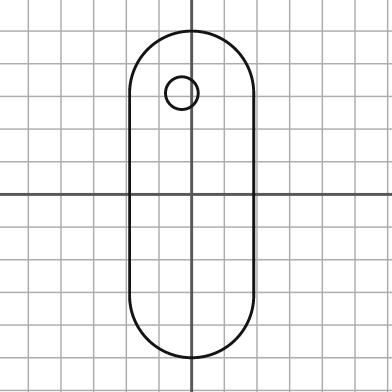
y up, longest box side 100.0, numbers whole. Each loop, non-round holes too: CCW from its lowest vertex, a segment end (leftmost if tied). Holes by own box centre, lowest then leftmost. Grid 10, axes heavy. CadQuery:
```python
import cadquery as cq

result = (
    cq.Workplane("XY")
    .moveTo(-19.0, -31.0)
    .threePointArc((0.0, -50.0), (19.0, -31.0))
    .lineTo(19.0, 31.0)
    .threePointArc((0.0, 50.0), (-19.0, 31.0))
    .close()
    .moveTo(-3.0, 31.0)
    .circle(5.0)
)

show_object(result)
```